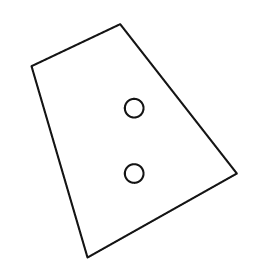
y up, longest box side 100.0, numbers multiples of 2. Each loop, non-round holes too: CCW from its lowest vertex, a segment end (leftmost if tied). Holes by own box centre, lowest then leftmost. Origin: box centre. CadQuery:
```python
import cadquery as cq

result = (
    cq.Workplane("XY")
    .moveTo(-20.0, -50.0)
    .lineTo(44.0, -14.0)
    .lineTo(-6.0, 50.0)
    .lineTo(-44.0, 32.0)
    .close()
    .moveTo(0.0, -14.0)
    .circle(4.0)
    .moveTo(0.0, 14.0)
    .circle(4.0)
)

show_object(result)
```